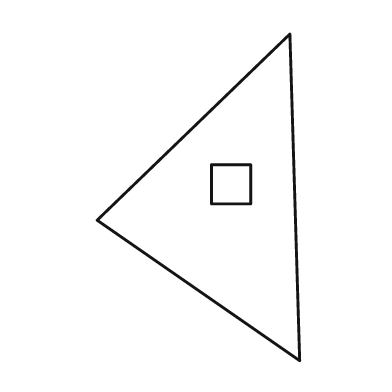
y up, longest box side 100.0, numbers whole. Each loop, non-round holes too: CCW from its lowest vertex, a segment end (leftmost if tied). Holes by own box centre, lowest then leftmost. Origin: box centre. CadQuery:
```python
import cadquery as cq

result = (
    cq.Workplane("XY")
    .moveTo(31.0, -50.0)
    .lineTo(28.0, 50.0)
    .lineTo(-31.0, -7.0)
    .close()
    .moveTo(4.0, -2.0)
    .lineTo(16.0, -2.0)
    .lineTo(16.0, 10.0)
    .lineTo(4.0, 10.0)
    .close()
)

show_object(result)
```